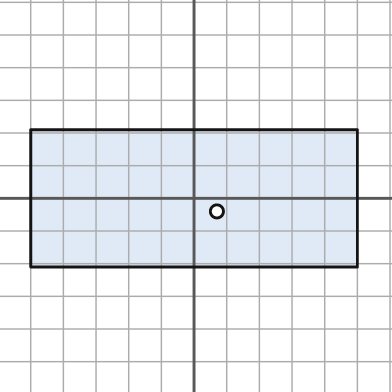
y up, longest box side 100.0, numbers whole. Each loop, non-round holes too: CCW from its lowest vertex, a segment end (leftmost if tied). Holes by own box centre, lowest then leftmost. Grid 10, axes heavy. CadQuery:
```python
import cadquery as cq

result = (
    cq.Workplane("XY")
    .moveTo(-50.0, -21.0)
    .lineTo(50.0, -21.0)
    .lineTo(50.0, 21.0)
    .lineTo(-50.0, 21.0)
    .close()
    .moveTo(7.0, -4.0)
    .circle(2.0)
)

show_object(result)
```